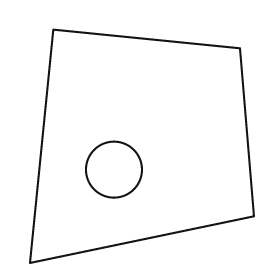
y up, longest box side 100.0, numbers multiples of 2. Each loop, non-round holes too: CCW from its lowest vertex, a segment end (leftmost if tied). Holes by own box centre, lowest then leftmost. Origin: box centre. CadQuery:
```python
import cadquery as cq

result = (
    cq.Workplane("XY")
    .moveTo(-48.0, -50.0)
    .lineTo(48.0, -30.0)
    .lineTo(42.0, 42.0)
    .lineTo(-38.0, 50.0)
    .close()
    .moveTo(-12.0, -10.0)
    .circle(12.0)
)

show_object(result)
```